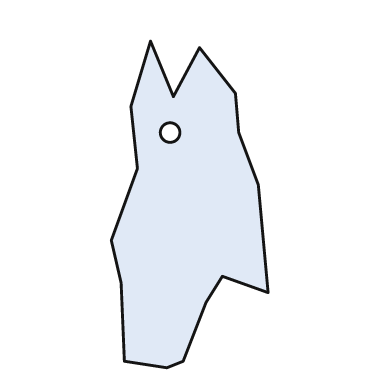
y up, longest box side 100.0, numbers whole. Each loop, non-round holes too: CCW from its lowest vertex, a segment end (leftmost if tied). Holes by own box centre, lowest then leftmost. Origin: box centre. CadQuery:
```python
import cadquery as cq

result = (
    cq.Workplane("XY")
    .moveTo(-7.0, -50.0)
    .lineTo(-2.0, -48.0)
    .lineTo(5.0, -30.0)
    .lineTo(10.0, -22.0)
    .lineTo(24.0, -27.0)
    .lineTo(21.0, 6.0)
    .lineTo(15.0, 22.0)
    .lineTo(14.0, 34.0)
    .lineTo(3.0, 48.0)
    .lineTo(-5.0, 33.0)
    .lineTo(-12.0, 50.0)
    .lineTo(-18.0, 30.0)
    .lineTo(-16.0, 11.0)
    .lineTo(-24.0, -11.0)
    .lineTo(-21.0, -24.0)
    .lineTo(-20.0, -48.0)
    .close()
    .moveTo(-6.0, 22.0)
    .circle(3.0)
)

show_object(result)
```